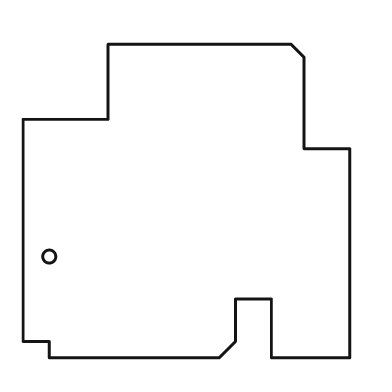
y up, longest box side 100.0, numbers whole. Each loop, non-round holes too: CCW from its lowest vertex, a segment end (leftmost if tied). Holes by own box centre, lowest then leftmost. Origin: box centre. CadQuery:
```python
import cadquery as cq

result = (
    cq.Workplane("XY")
    .moveTo(-42.0, -48.0)
    .lineTo(10.0, -48.0)
    .lineTo(15.0, -43.0)
    .lineTo(15.0, -30.0)
    .lineTo(26.0, -30.0)
    .lineTo(26.0, -48.0)
    .lineTo(50.0, -48.0)
    .lineTo(50.0, 16.0)
    .lineTo(36.0, 16.0)
    .lineTo(36.0, 44.0)
    .lineTo(32.0, 48.0)
    .lineTo(-24.0, 48.0)
    .lineTo(-24.0, 25.0)
    .lineTo(-50.0, 25.0)
    .lineTo(-50.0, -43.0)
    .lineTo(-42.0, -43.0)
    .close()
    .moveTo(-42.0, -17.0)
    .circle(2.0)
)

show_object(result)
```